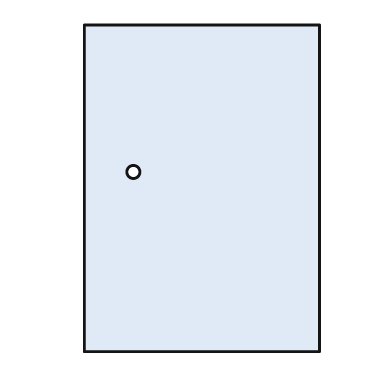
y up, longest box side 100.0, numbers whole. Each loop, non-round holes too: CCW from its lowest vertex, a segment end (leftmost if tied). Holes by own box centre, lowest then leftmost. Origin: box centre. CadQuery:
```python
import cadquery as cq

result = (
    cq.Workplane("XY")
    .moveTo(-36.0, -50.0)
    .lineTo(36.0, -50.0)
    .lineTo(36.0, 50.0)
    .lineTo(-36.0, 50.0)
    .close()
    .moveTo(-21.0, 5.0)
    .circle(2.0)
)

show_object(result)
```